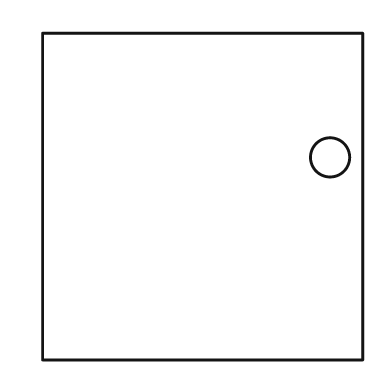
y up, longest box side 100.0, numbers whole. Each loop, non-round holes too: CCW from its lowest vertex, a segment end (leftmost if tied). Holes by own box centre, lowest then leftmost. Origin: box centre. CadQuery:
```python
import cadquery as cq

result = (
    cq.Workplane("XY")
    .moveTo(-49.0, -50.0)
    .lineTo(49.0, -50.0)
    .lineTo(49.0, 50.0)
    .lineTo(-49.0, 50.0)
    .close()
    .moveTo(39.0, 12.0)
    .circle(6.0)
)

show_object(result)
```